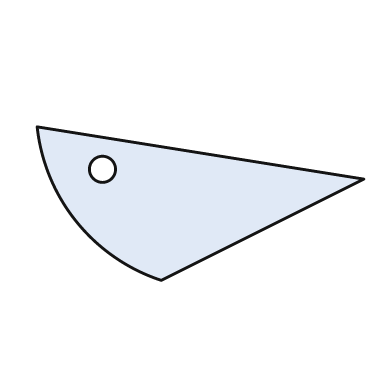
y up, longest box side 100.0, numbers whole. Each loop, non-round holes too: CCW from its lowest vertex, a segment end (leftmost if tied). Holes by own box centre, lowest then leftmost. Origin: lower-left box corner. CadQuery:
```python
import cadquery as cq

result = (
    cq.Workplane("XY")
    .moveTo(38.0, 0.0)
    .lineTo(100.0, 31.0)
    .lineTo(0.0, 47.0)
    .threePointArc((12.0, 18.0), (38.0, 0.0))
    .close()
    .moveTo(20.0, 34.0)
    .circle(4.0)
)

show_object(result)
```